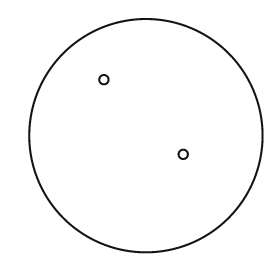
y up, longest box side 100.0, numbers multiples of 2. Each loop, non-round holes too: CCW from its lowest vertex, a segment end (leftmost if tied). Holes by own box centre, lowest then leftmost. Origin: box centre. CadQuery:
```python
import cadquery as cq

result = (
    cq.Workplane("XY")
    .moveTo(0.0, 0.0)
    .circle(50.0)
    .moveTo(16.0, -8.0)
    .circle(2.0)
    .moveTo(-18.0, 24.0)
    .circle(2.0)
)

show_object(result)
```